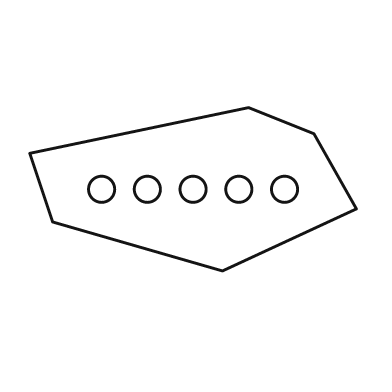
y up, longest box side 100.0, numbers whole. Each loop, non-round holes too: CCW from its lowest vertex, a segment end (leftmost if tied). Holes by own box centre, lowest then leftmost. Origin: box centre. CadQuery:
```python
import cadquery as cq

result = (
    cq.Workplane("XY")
    .moveTo(9.0, -25.0)
    .lineTo(50.0, -6.0)
    .lineTo(37.0, 17.0)
    .lineTo(17.0, 25.0)
    .lineTo(-50.0, 11.0)
    .lineTo(-43.0, -10.0)
    .close()
    .moveTo(-28.0, 0.0)
    .circle(4.0)
    .moveTo(-14.0, 0.0)
    .circle(4.0)
    .moveTo(0.0, 0.0)
    .circle(4.0)
    .moveTo(14.0, 0.0)
    .circle(4.0)
    .moveTo(28.0, 0.0)
    .circle(4.0)
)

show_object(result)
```